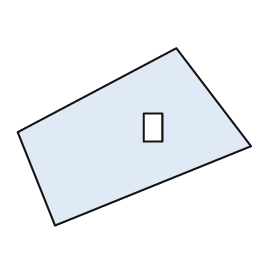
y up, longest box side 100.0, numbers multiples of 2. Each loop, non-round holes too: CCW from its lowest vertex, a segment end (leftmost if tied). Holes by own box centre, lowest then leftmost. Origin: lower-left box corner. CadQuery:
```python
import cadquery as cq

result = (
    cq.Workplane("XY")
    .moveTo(16.0, 0.0)
    .lineTo(100.0, 34.0)
    .lineTo(68.0, 76.0)
    .lineTo(0.0, 40.0)
    .close()
    .moveTo(54.0, 36.0)
    .lineTo(62.0, 36.0)
    .lineTo(62.0, 48.0)
    .lineTo(54.0, 48.0)
    .close()
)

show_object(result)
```